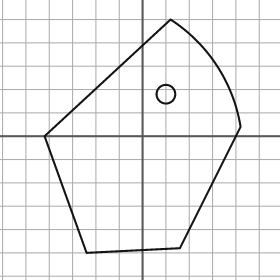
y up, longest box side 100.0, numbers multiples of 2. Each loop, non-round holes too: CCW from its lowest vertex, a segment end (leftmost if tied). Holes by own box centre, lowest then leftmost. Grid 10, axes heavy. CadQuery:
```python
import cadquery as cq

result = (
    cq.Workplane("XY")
    .moveTo(-24.0, -50.0)
    .lineTo(16.0, -48.0)
    .lineTo(42.0, 4.0)
    .threePointArc((32.0, 30.0), (12.0, 50.0))
    .lineTo(-42.0, 0.0)
    .close()
    .moveTo(10.0, 18.0)
    .circle(4.0)
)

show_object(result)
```